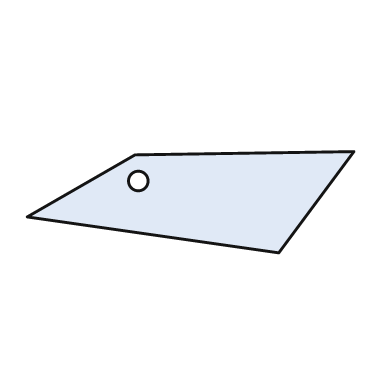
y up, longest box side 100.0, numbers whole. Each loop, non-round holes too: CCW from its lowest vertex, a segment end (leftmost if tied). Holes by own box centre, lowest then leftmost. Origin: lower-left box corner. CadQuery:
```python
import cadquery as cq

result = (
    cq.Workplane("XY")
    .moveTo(77.0, 0.0)
    .lineTo(100.0, 31.0)
    .lineTo(33.0, 30.0)
    .lineTo(0.0, 11.0)
    .close()
    .moveTo(34.0, 22.0)
    .circle(3.0)
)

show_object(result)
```